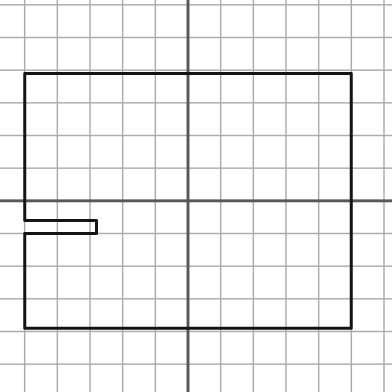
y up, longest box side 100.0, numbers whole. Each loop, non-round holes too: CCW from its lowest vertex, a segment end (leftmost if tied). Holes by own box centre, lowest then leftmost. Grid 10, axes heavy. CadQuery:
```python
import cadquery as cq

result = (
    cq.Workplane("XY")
    .moveTo(-50.0, -39.0)
    .lineTo(50.0, -39.0)
    .lineTo(50.0, 39.0)
    .lineTo(-50.0, 39.0)
    .lineTo(-50.0, -6.0)
    .lineTo(-28.0, -6.0)
    .lineTo(-28.0, -10.0)
    .lineTo(-50.0, -10.0)
    .close()
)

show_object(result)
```